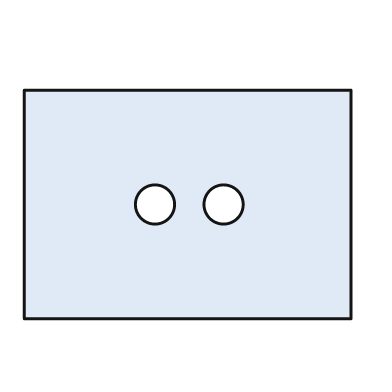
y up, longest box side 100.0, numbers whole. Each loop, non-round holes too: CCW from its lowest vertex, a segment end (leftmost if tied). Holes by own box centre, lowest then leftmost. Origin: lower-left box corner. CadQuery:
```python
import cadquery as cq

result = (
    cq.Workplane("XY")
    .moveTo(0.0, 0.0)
    .lineTo(100.0, 0.0)
    .lineTo(100.0, 70.0)
    .lineTo(0.0, 70.0)
    .close()
    .moveTo(40.0, 35.0)
    .circle(6.0)
    .moveTo(61.0, 35.0)
    .circle(6.0)
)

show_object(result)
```